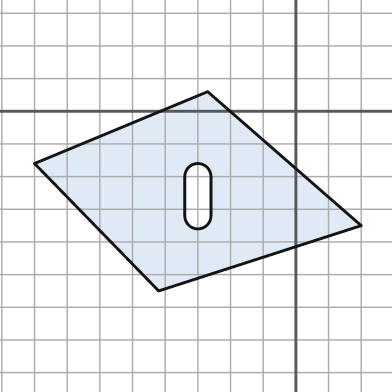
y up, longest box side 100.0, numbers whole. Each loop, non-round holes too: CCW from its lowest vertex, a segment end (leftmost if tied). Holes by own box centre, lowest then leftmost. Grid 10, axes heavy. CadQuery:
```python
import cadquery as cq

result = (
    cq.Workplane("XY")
    .moveTo(-42.0, -55.0)
    .lineTo(20.0, -35.0)
    .lineTo(-27.0, 6.0)
    .lineTo(-80.0, -16.0)
    .close()
    .moveTo(-34.0, -32.0)
    .threePointArc((-30.0, -36.0), (-26.0, -32.0))
    .lineTo(-26.0, -20.0)
    .threePointArc((-30.0, -16.0), (-34.0, -20.0))
    .close()
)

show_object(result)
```